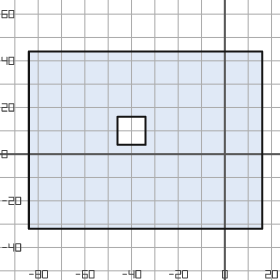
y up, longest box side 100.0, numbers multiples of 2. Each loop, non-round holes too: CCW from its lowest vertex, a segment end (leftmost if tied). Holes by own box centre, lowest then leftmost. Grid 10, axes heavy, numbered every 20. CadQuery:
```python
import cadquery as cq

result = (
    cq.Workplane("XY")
    .moveTo(-84.0, -32.0)
    .lineTo(16.0, -32.0)
    .lineTo(16.0, 44.0)
    .lineTo(-84.0, 44.0)
    .close()
    .moveTo(-46.0, 4.0)
    .lineTo(-34.0, 4.0)
    .lineTo(-34.0, 16.0)
    .lineTo(-46.0, 16.0)
    .close()
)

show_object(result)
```